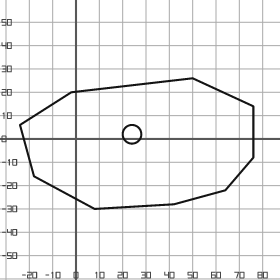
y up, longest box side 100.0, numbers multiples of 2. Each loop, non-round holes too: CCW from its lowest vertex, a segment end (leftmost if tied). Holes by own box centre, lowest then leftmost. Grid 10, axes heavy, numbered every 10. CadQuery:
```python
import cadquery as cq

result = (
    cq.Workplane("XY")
    .moveTo(8.0, -30.0)
    .lineTo(42.0, -28.0)
    .lineTo(64.0, -22.0)
    .lineTo(76.0, -8.0)
    .lineTo(76.0, 14.0)
    .lineTo(50.0, 26.0)
    .lineTo(-2.0, 20.0)
    .lineTo(-24.0, 6.0)
    .lineTo(-18.0, -16.0)
    .close()
    .moveTo(24.0, 2.0)
    .circle(4.0)
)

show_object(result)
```